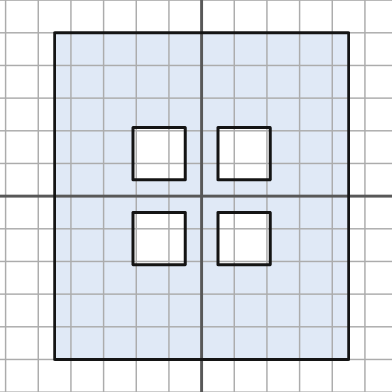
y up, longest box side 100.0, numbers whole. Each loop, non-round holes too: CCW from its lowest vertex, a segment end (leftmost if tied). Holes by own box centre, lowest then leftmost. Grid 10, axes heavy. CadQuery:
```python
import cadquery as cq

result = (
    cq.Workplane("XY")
    .moveTo(-45.0, -50.0)
    .lineTo(45.0, -50.0)
    .lineTo(45.0, 50.0)
    .lineTo(-45.0, 50.0)
    .close()
    .moveTo(-21.0, -21.0)
    .lineTo(-5.0, -21.0)
    .lineTo(-5.0, -5.0)
    .lineTo(-21.0, -5.0)
    .close()
    .moveTo(5.0, -21.0)
    .lineTo(21.0, -21.0)
    .lineTo(21.0, -5.0)
    .lineTo(5.0, -5.0)
    .close()
    .moveTo(-21.0, 5.0)
    .lineTo(-5.0, 5.0)
    .lineTo(-5.0, 21.0)
    .lineTo(-21.0, 21.0)
    .close()
    .moveTo(5.0, 5.0)
    .lineTo(21.0, 5.0)
    .lineTo(21.0, 21.0)
    .lineTo(5.0, 21.0)
    .close()
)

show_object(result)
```